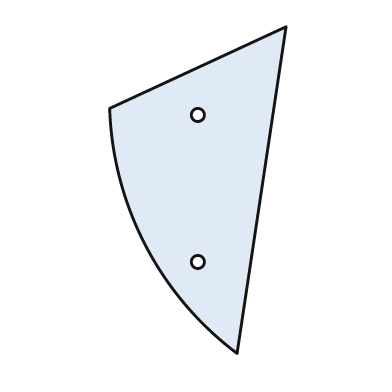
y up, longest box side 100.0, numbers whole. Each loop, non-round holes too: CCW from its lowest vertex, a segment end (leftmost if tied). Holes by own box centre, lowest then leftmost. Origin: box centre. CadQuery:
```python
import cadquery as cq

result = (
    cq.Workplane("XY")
    .moveTo(12.0, -50.0)
    .lineTo(27.0, 50.0)
    .lineTo(-27.0, 25.0)
    .threePointArc((-16.0, -17.0), (12.0, -50.0))
    .close()
    .moveTo(0.0, -22.0)
    .circle(2.0)
    .moveTo(0.0, 23.0)
    .circle(2.0)
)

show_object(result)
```